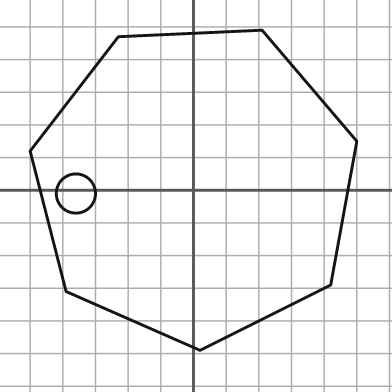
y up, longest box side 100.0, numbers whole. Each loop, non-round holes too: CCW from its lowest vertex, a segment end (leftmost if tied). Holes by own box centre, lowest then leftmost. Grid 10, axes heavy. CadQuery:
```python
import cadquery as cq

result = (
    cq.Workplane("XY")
    .moveTo(2.0, -49.0)
    .lineTo(42.0, -29.0)
    .lineTo(50.0, 15.0)
    .lineTo(21.0, 49.0)
    .lineTo(-23.0, 47.0)
    .lineTo(-50.0, 12.0)
    .lineTo(-39.0, -31.0)
    .close()
    .moveTo(-36.0, -1.0)
    .circle(6.0)
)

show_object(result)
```